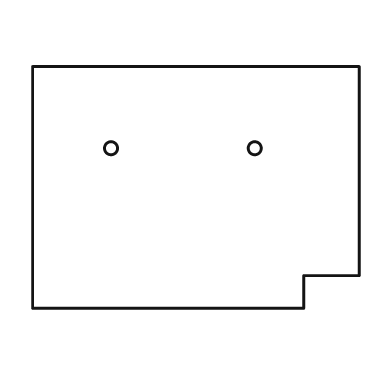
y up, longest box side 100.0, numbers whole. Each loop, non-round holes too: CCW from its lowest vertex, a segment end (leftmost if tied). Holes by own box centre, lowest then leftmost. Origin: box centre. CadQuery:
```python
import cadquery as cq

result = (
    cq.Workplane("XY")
    .moveTo(-50.0, -37.0)
    .lineTo(33.0, -37.0)
    .lineTo(33.0, -27.0)
    .lineTo(50.0, -27.0)
    .lineTo(50.0, 37.0)
    .lineTo(-50.0, 37.0)
    .close()
    .moveTo(-26.0, 12.0)
    .circle(2.0)
    .moveTo(18.0, 12.0)
    .circle(2.0)
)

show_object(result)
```